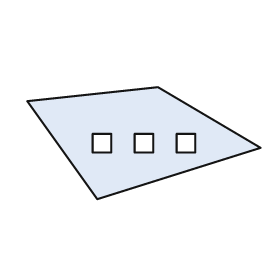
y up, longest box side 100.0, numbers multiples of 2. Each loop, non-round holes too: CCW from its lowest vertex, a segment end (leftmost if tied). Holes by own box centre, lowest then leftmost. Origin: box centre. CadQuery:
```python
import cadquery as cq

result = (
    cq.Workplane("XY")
    .moveTo(-20.0, -24.0)
    .lineTo(50.0, -2.0)
    .lineTo(6.0, 24.0)
    .lineTo(-50.0, 18.0)
    .close()
    .moveTo(-22.0, -4.0)
    .lineTo(-14.0, -4.0)
    .lineTo(-14.0, 4.0)
    .lineTo(-22.0, 4.0)
    .close()
    .moveTo(-4.0, -4.0)
    .lineTo(4.0, -4.0)
    .lineTo(4.0, 4.0)
    .lineTo(-4.0, 4.0)
    .close()
    .moveTo(14.0, -4.0)
    .lineTo(22.0, -4.0)
    .lineTo(22.0, 4.0)
    .lineTo(14.0, 4.0)
    .close()
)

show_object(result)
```